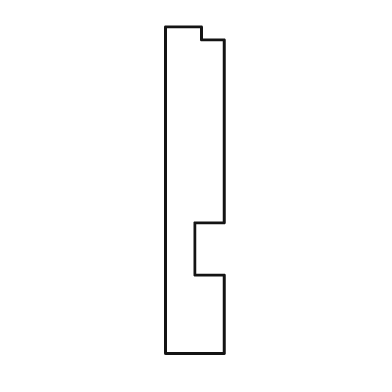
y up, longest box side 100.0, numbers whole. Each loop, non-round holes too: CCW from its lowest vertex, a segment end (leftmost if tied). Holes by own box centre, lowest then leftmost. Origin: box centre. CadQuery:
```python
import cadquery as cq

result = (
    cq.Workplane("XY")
    .moveTo(-9.0, -50.0)
    .lineTo(9.0, -50.0)
    .lineTo(9.0, -26.0)
    .lineTo(0.0, -26.0)
    .lineTo(0.0, -10.0)
    .lineTo(9.0, -10.0)
    .lineTo(9.0, 46.0)
    .lineTo(2.0, 46.0)
    .lineTo(2.0, 50.0)
    .lineTo(-9.0, 50.0)
    .close()
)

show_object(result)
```